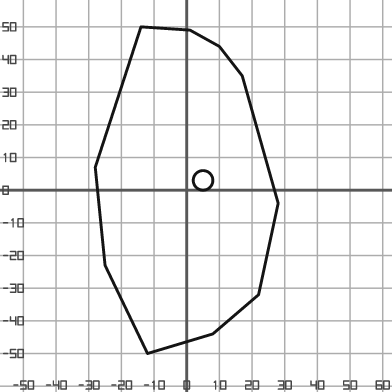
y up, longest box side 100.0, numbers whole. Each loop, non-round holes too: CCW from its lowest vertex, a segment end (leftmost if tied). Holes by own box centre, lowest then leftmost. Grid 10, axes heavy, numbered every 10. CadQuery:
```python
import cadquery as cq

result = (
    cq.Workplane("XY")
    .moveTo(-12.0, -50.0)
    .lineTo(8.0, -44.0)
    .lineTo(22.0, -32.0)
    .lineTo(28.0, -4.0)
    .lineTo(17.0, 35.0)
    .lineTo(10.0, 44.0)
    .lineTo(1.0, 49.0)
    .lineTo(-14.0, 50.0)
    .lineTo(-28.0, 7.0)
    .lineTo(-25.0, -23.0)
    .close()
    .moveTo(5.0, 3.0)
    .circle(3.0)
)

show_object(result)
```